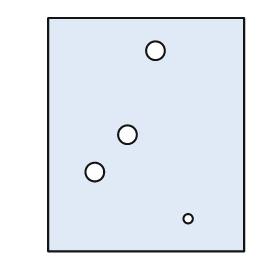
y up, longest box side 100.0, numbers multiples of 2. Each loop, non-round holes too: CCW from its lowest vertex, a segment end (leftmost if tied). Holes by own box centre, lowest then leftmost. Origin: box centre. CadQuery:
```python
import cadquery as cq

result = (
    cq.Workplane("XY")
    .moveTo(-42.0, -50.0)
    .lineTo(42.0, -50.0)
    .lineTo(42.0, 50.0)
    .lineTo(-42.0, 50.0)
    .close()
    .moveTo(18.0, -36.0)
    .circle(2.0)
    .moveTo(-22.0, -16.0)
    .circle(4.0)
    .moveTo(-8.0, 0.0)
    .circle(4.0)
    .moveTo(4.0, 36.0)
    .circle(4.0)
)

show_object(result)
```